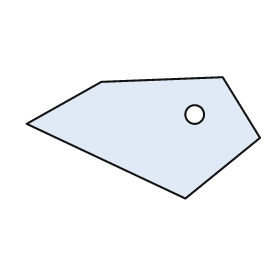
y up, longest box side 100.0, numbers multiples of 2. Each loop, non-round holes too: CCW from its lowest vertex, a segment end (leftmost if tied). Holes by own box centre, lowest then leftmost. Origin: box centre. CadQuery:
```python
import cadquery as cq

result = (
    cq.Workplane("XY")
    .moveTo(18.0, -26.0)
    .lineTo(50.0, 0.0)
    .lineTo(34.0, 26.0)
    .lineTo(-18.0, 24.0)
    .lineTo(-50.0, 6.0)
    .close()
    .moveTo(22.0, 10.0)
    .circle(4.0)
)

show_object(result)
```